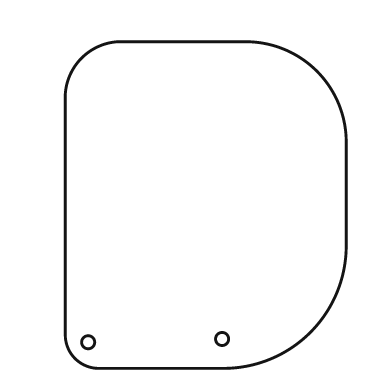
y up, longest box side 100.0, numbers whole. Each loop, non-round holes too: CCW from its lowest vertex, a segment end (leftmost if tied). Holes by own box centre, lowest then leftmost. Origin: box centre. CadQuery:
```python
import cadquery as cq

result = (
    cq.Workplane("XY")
    .moveTo(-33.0, -50.0)
    .lineTo(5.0, -50.0)
    .threePointArc((32.0, -39.0), (43.0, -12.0))
    .lineTo(43.0, 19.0)
    .threePointArc((34.0, 41.0), (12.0, 50.0))
    .lineTo(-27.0, 50.0)
    .threePointArc((-38.0, 45.0), (-43.0, 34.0))
    .lineTo(-43.0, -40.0)
    .threePointArc((-40.0, -47.0), (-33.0, -50.0))
    .close()
    .moveTo(-36.0, -42.0)
    .circle(2.0)
    .moveTo(5.0, -41.0)
    .circle(2.0)
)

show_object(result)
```